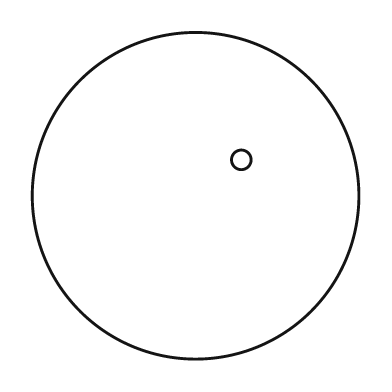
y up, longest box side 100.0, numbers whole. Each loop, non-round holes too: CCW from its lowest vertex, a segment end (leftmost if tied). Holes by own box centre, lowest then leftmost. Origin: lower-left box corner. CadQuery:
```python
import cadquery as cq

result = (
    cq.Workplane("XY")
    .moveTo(50.0, 50.0)
    .circle(50.0)
    .moveTo(64.0, 61.0)
    .circle(3.0)
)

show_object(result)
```